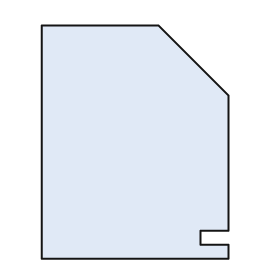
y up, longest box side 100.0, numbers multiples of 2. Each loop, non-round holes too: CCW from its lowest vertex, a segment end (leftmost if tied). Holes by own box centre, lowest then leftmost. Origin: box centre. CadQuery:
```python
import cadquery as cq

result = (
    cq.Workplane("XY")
    .moveTo(-40.0, -50.0)
    .lineTo(40.0, -50.0)
    .lineTo(40.0, -44.0)
    .lineTo(28.0, -44.0)
    .lineTo(28.0, -38.0)
    .lineTo(40.0, -38.0)
    .lineTo(40.0, 20.0)
    .lineTo(10.0, 50.0)
    .lineTo(-40.0, 50.0)
    .close()
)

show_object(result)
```